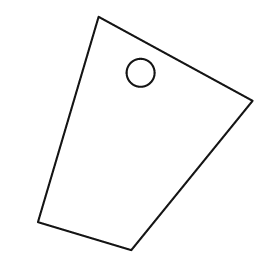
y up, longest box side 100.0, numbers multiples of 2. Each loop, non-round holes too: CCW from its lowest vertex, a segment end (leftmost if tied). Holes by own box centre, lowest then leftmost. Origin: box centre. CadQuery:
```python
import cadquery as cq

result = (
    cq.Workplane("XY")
    .moveTo(-6.0, -50.0)
    .lineTo(46.0, 14.0)
    .lineTo(-20.0, 50.0)
    .lineTo(-46.0, -38.0)
    .close()
    .moveTo(-2.0, 26.0)
    .circle(6.0)
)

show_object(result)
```